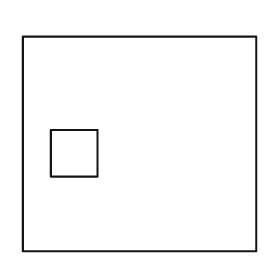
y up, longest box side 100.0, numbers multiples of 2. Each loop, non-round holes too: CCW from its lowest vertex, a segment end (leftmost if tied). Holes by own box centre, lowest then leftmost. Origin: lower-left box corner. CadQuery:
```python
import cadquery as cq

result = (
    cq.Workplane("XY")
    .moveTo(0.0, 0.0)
    .lineTo(100.0, 0.0)
    .lineTo(100.0, 92.0)
    .lineTo(0.0, 92.0)
    .close()
    .moveTo(12.0, 32.0)
    .lineTo(32.0, 32.0)
    .lineTo(32.0, 52.0)
    .lineTo(12.0, 52.0)
    .close()
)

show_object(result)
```